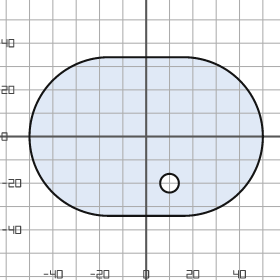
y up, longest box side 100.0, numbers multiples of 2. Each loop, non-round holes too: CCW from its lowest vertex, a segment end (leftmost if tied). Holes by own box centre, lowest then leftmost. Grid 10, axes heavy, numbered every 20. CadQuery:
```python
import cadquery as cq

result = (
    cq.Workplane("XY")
    .moveTo(-16.0, -34.0)
    .lineTo(16.0, -34.0)
    .threePointArc((50.0, 0.0), (16.0, 34.0))
    .lineTo(-16.0, 34.0)
    .threePointArc((-50.0, 0.0), (-16.0, -34.0))
    .close()
    .moveTo(10.0, -20.0)
    .circle(4.0)
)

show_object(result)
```